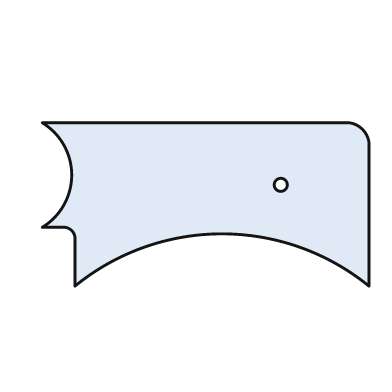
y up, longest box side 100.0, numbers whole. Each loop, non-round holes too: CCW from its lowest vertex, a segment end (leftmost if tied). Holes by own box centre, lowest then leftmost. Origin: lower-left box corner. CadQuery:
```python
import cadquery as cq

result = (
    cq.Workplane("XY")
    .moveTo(10.0, 0.0)
    .threePointArc((55.0, 16.0), (100.0, 0.0))
    .lineTo(100.0, 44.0)
    .threePointArc((98.0, 48.0), (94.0, 50.0))
    .lineTo(0.0, 50.0)
    .threePointArc((9.0, 34.0), (0.0, 18.0))
    .lineTo(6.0, 18.0)
    .threePointArc((9.0, 17.0), (10.0, 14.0))
    .close()
    .moveTo(73.0, 31.0)
    .circle(2.0)
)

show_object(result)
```